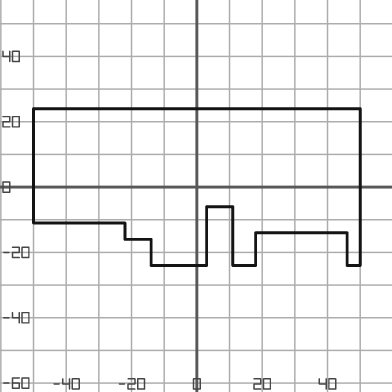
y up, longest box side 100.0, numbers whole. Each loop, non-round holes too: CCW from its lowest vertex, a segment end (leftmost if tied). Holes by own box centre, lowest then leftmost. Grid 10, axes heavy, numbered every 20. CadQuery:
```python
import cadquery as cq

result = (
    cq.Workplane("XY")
    .moveTo(-14.0, -24.0)
    .lineTo(3.0, -24.0)
    .lineTo(3.0, -6.0)
    .lineTo(11.0, -6.0)
    .lineTo(11.0, -24.0)
    .lineTo(18.0, -24.0)
    .lineTo(18.0, -14.0)
    .lineTo(46.0, -14.0)
    .lineTo(46.0, -24.0)
    .lineTo(50.0, -24.0)
    .lineTo(50.0, 24.0)
    .lineTo(-50.0, 24.0)
    .lineTo(-50.0, -11.0)
    .lineTo(-22.0, -11.0)
    .lineTo(-22.0, -16.0)
    .lineTo(-14.0, -16.0)
    .close()
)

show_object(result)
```